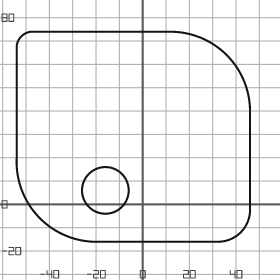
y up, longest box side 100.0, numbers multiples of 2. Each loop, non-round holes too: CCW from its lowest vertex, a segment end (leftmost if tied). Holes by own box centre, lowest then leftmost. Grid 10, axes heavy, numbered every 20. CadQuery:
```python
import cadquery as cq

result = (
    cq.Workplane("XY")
    .moveTo(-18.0, -16.0)
    .lineTo(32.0, -16.0)
    .threePointArc((42.0, -12.0), (46.0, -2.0))
    .lineTo(46.0, 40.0)
    .threePointArc((36.0, 64.0), (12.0, 74.0))
    .lineTo(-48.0, 74.0)
    .threePointArc((-52.0, 72.0), (-54.0, 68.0))
    .lineTo(-54.0, 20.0)
    .threePointArc((-44.0, -6.0), (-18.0, -16.0))
    .close()
    .moveTo(-16.0, 6.0)
    .circle(10.0)
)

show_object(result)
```